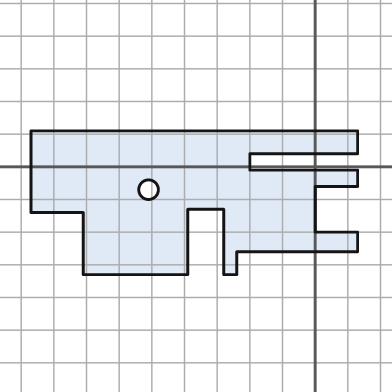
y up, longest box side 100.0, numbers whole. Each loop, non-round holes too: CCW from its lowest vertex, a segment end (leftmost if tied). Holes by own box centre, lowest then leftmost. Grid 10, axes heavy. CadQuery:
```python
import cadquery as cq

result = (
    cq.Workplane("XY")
    .moveTo(-71.0, -33.0)
    .lineTo(-39.0, -33.0)
    .lineTo(-39.0, -13.0)
    .lineTo(-28.0, -13.0)
    .lineTo(-28.0, -33.0)
    .lineTo(-24.0, -33.0)
    .lineTo(-24.0, -26.0)
    .lineTo(13.0, -26.0)
    .lineTo(13.0, -20.0)
    .lineTo(0.0, -20.0)
    .lineTo(0.0, -6.0)
    .lineTo(13.0, -6.0)
    .lineTo(13.0, -1.0)
    .lineTo(-20.0, -1.0)
    .lineTo(-20.0, 4.0)
    .lineTo(13.0, 4.0)
    .lineTo(13.0, 11.0)
    .lineTo(-87.0, 11.0)
    .lineTo(-87.0, -14.0)
    .lineTo(-71.0, -14.0)
    .close()
    .moveTo(-51.0, -7.0)
    .circle(3.0)
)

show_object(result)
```